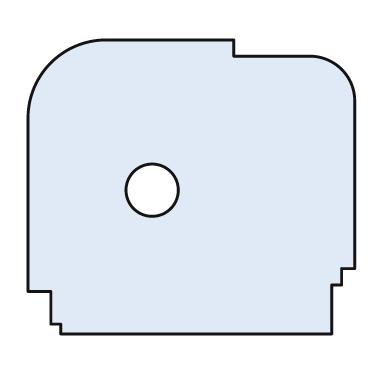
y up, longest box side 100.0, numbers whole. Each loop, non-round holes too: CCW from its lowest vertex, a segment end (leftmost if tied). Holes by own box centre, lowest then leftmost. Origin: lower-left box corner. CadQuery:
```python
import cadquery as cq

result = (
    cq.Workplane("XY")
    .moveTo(10.0, 0.0)
    .lineTo(93.0, 0.0)
    .lineTo(93.0, 15.0)
    .lineTo(96.0, 15.0)
    .lineTo(96.0, 20.0)
    .lineTo(100.0, 20.0)
    .lineTo(100.0, 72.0)
    .threePointArc((96.0, 81.0), (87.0, 85.0))
    .lineTo(63.0, 85.0)
    .lineTo(63.0, 90.0)
    .lineTo(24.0, 90.0)
    .threePointArc((7.0, 83.0), (0.0, 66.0))
    .lineTo(0.0, 13.0)
    .lineTo(7.0, 13.0)
    .lineTo(7.0, 3.0)
    .lineTo(10.0, 3.0)
    .close()
    .moveTo(38.0, 44.0)
    .circle(8.0)
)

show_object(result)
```